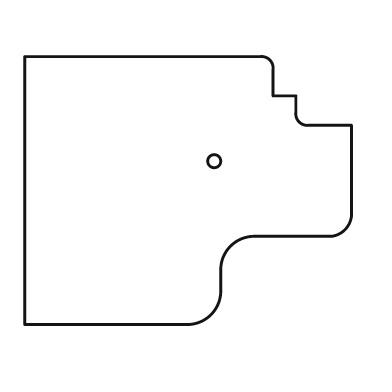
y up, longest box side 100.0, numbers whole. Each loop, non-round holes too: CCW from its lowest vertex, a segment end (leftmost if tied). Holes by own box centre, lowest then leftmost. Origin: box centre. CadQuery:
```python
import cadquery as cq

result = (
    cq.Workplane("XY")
    .moveTo(-50.0, -41.0)
    .lineTo(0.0, -41.0)
    .threePointArc((7.0, -38.0), (10.0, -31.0))
    .lineTo(10.0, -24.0)
    .threePointArc((13.0, -17.0), (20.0, -14.0))
    .lineTo(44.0, -14.0)
    .threePointArc((48.0, -12.0), (50.0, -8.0))
    .lineTo(50.0, 20.0)
    .lineTo(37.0, 20.0)
    .threePointArc((34.0, 21.0), (33.0, 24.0))
    .lineTo(33.0, 29.0)
    .lineTo(26.0, 29.0)
    .lineTo(26.0, 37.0)
    .threePointArc((25.0, 40.0), (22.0, 41.0))
    .lineTo(-50.0, 41.0)
    .close()
    .moveTo(8.0, 9.0)
    .circle(2.0)
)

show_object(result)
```